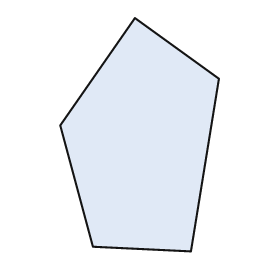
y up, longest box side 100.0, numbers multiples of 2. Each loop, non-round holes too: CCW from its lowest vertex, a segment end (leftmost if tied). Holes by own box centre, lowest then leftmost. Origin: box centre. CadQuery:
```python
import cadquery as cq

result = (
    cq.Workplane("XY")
    .moveTo(22.0, -50.0)
    .lineTo(34.0, 24.0)
    .lineTo(-2.0, 50.0)
    .lineTo(-34.0, 4.0)
    .lineTo(-20.0, -48.0)
    .close()
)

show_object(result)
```